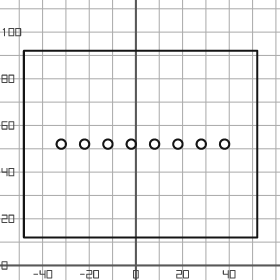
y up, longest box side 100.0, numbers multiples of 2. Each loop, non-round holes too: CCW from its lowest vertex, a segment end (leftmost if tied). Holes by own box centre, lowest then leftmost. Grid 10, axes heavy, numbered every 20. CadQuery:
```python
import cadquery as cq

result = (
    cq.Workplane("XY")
    .moveTo(-48.0, 12.0)
    .lineTo(52.0, 12.0)
    .lineTo(52.0, 92.0)
    .lineTo(-48.0, 92.0)
    .close()
    .moveTo(-32.0, 52.0)
    .circle(2.0)
    .moveTo(-22.0, 52.0)
    .circle(2.0)
    .moveTo(-12.0, 52.0)
    .circle(2.0)
    .moveTo(-2.0, 52.0)
    .circle(2.0)
    .moveTo(8.0, 52.0)
    .circle(2.0)
    .moveTo(18.0, 52.0)
    .circle(2.0)
    .moveTo(28.0, 52.0)
    .circle(2.0)
    .moveTo(38.0, 52.0)
    .circle(2.0)
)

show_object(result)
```